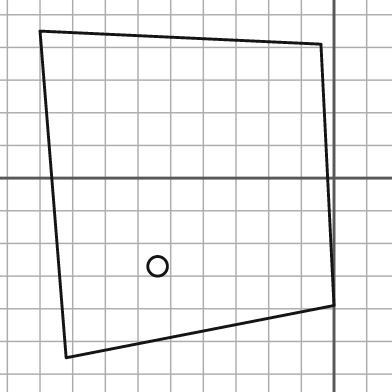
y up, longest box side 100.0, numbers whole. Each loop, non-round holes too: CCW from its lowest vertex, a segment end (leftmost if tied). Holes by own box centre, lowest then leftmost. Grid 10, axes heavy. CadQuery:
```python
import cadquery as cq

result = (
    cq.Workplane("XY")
    .moveTo(-82.0, -55.0)
    .lineTo(0.0, -39.0)
    .lineTo(-4.0, 41.0)
    .lineTo(-90.0, 45.0)
    .close()
    .moveTo(-54.0, -27.0)
    .circle(3.0)
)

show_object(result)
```